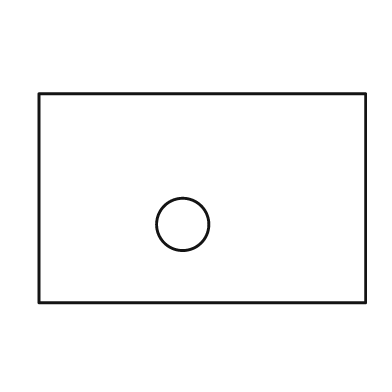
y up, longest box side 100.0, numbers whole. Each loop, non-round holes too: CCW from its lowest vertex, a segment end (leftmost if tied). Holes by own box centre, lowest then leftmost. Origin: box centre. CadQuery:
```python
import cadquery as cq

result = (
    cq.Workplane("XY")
    .moveTo(-50.0, -32.0)
    .lineTo(50.0, -32.0)
    .lineTo(50.0, 32.0)
    .lineTo(-50.0, 32.0)
    .close()
    .moveTo(-6.0, -8.0)
    .circle(8.0)
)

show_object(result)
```